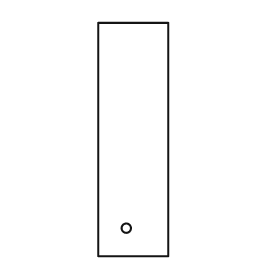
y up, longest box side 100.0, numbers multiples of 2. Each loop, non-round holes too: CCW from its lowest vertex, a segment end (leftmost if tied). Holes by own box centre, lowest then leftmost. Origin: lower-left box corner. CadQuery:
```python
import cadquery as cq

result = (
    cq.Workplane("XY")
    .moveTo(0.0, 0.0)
    .lineTo(30.0, 0.0)
    .lineTo(30.0, 100.0)
    .lineTo(0.0, 100.0)
    .close()
    .moveTo(12.0, 12.0)
    .circle(2.0)
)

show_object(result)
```